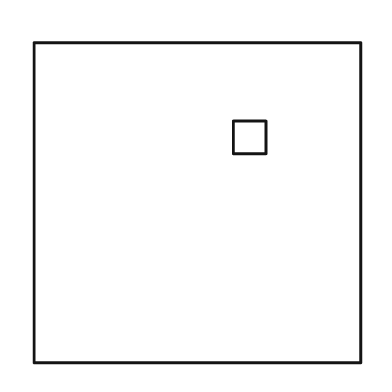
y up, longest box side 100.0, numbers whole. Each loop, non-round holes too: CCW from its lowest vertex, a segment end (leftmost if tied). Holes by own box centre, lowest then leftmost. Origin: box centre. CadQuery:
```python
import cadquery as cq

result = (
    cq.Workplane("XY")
    .moveTo(-50.0, -49.0)
    .lineTo(50.0, -49.0)
    .lineTo(50.0, 49.0)
    .lineTo(-50.0, 49.0)
    .close()
    .moveTo(11.0, 15.0)
    .lineTo(21.0, 15.0)
    .lineTo(21.0, 25.0)
    .lineTo(11.0, 25.0)
    .close()
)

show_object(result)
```